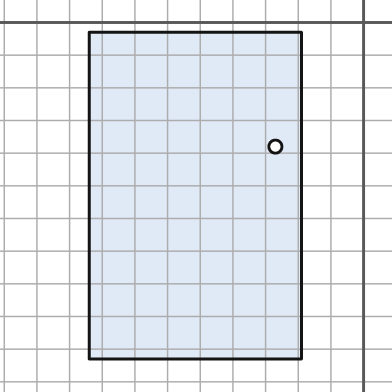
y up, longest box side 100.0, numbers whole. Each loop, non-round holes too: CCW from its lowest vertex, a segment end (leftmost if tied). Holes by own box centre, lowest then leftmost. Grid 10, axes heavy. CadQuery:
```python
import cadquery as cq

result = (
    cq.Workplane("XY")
    .moveTo(-84.0, -103.0)
    .lineTo(-19.0, -103.0)
    .lineTo(-19.0, -3.0)
    .lineTo(-84.0, -3.0)
    .close()
    .moveTo(-27.0, -38.0)
    .circle(2.0)
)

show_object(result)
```